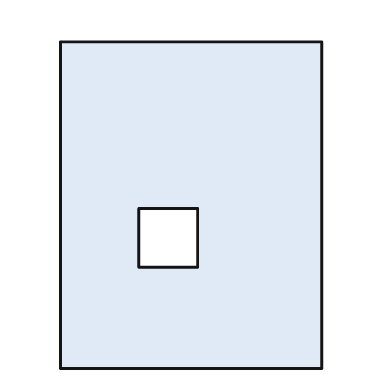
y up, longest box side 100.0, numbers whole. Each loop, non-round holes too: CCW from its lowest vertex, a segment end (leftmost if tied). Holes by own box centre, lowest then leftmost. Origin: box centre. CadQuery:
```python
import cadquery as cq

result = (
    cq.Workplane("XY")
    .moveTo(-40.0, -50.0)
    .lineTo(40.0, -50.0)
    .lineTo(40.0, 50.0)
    .lineTo(-40.0, 50.0)
    .close()
    .moveTo(-16.0, -19.0)
    .lineTo(2.0, -19.0)
    .lineTo(2.0, -1.0)
    .lineTo(-16.0, -1.0)
    .close()
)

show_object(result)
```